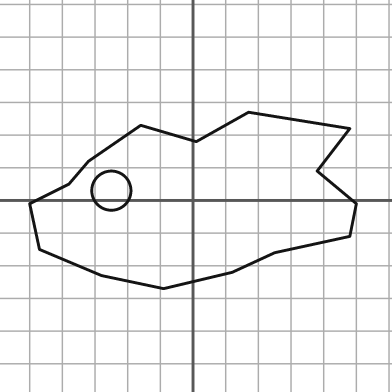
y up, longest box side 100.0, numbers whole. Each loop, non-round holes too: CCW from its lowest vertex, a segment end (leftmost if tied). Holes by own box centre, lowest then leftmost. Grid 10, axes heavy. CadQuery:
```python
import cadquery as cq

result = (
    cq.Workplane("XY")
    .moveTo(-9.0, -27.0)
    .lineTo(12.0, -22.0)
    .lineTo(25.0, -16.0)
    .lineTo(48.0, -11.0)
    .lineTo(50.0, -1.0)
    .lineTo(38.0, 9.0)
    .lineTo(48.0, 22.0)
    .lineTo(17.0, 27.0)
    .lineTo(1.0, 18.0)
    .lineTo(-16.0, 23.0)
    .lineTo(-32.0, 12.0)
    .lineTo(-38.0, 5.0)
    .lineTo(-50.0, -1.0)
    .lineTo(-47.0, -15.0)
    .lineTo(-28.0, -23.0)
    .close()
    .moveTo(-25.0, 3.0)
    .circle(6.0)
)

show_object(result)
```